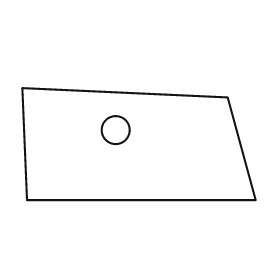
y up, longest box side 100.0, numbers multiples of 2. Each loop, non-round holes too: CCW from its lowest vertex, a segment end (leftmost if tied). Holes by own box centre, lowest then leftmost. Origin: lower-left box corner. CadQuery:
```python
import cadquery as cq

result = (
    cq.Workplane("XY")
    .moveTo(2.0, 0.0)
    .lineTo(100.0, 0.0)
    .lineTo(88.0, 44.0)
    .lineTo(0.0, 48.0)
    .close()
    .moveTo(40.0, 30.0)
    .circle(6.0)
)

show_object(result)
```